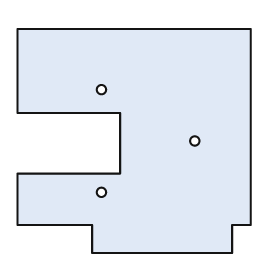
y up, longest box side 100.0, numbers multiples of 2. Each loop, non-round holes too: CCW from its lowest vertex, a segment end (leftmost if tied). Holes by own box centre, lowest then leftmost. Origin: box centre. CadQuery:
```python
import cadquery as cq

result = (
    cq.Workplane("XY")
    .moveTo(-18.0, -48.0)
    .lineTo(42.0, -48.0)
    .lineTo(42.0, -36.0)
    .lineTo(50.0, -36.0)
    .lineTo(50.0, 48.0)
    .lineTo(-50.0, 48.0)
    .lineTo(-50.0, 12.0)
    .lineTo(-6.0, 12.0)
    .lineTo(-6.0, -14.0)
    .lineTo(-50.0, -14.0)
    .lineTo(-50.0, -36.0)
    .lineTo(-18.0, -36.0)
    .close()
    .moveTo(-14.0, -22.0)
    .circle(2.0)
    .moveTo(26.0, 0.0)
    .circle(2.0)
    .moveTo(-14.0, 22.0)
    .circle(2.0)
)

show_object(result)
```